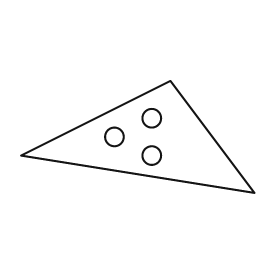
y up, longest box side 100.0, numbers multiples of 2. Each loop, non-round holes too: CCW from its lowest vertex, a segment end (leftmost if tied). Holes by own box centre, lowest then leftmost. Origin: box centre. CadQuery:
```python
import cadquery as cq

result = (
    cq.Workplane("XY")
    .moveTo(50.0, -24.0)
    .lineTo(14.0, 24.0)
    .lineTo(-50.0, -8.0)
    .close()
    .moveTo(6.0, -8.0)
    .circle(4.0)
    .moveTo(-10.0, 0.0)
    .circle(4.0)
    .moveTo(6.0, 8.0)
    .circle(4.0)
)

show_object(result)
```